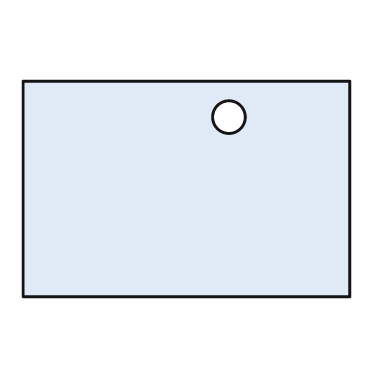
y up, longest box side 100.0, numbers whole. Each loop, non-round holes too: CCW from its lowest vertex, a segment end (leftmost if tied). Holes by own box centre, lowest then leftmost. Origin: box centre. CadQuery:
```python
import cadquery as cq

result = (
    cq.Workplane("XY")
    .moveTo(-50.0, -33.0)
    .lineTo(50.0, -33.0)
    .lineTo(50.0, 33.0)
    .lineTo(-50.0, 33.0)
    .close()
    .moveTo(13.0, 22.0)
    .circle(5.0)
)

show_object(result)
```